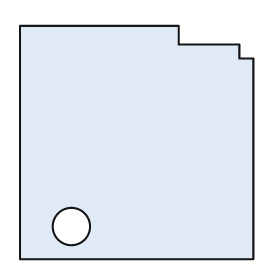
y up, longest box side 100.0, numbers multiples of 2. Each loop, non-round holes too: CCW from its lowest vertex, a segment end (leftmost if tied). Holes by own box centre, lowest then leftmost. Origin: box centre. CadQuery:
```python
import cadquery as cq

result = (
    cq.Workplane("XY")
    .moveTo(-50.0, -50.0)
    .lineTo(50.0, -50.0)
    .lineTo(50.0, 36.0)
    .lineTo(44.0, 36.0)
    .lineTo(44.0, 42.0)
    .lineTo(18.0, 42.0)
    .lineTo(18.0, 50.0)
    .lineTo(-50.0, 50.0)
    .close()
    .moveTo(-28.0, -36.0)
    .circle(8.0)
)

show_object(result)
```